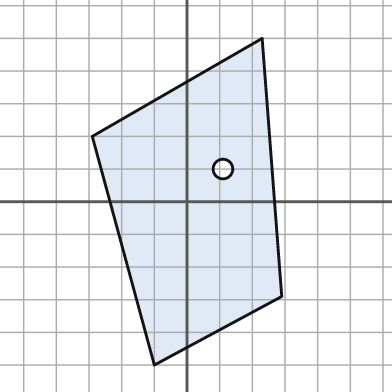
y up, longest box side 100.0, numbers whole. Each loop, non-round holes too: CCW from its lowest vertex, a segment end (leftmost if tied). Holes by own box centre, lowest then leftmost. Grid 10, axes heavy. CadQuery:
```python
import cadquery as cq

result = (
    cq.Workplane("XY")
    .moveTo(-10.0, -50.0)
    .lineTo(29.0, -29.0)
    .lineTo(23.0, 50.0)
    .lineTo(-29.0, 20.0)
    .close()
    .moveTo(11.0, 10.0)
    .circle(3.0)
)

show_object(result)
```